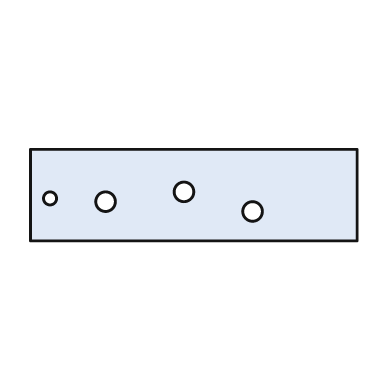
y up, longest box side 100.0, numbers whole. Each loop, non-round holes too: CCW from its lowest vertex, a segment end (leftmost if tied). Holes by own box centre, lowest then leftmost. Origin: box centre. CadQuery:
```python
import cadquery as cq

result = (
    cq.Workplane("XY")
    .moveTo(-50.0, -14.0)
    .lineTo(50.0, -14.0)
    .lineTo(50.0, 14.0)
    .lineTo(-50.0, 14.0)
    .close()
    .moveTo(18.0, -5.0)
    .circle(3.0)
    .moveTo(-27.0, -2.0)
    .circle(3.0)
    .moveTo(-44.0, -1.0)
    .circle(2.0)
    .moveTo(-3.0, 1.0)
    .circle(3.0)
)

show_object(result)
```